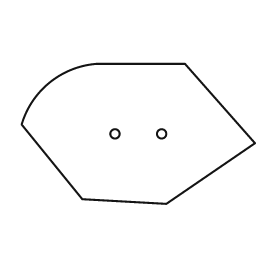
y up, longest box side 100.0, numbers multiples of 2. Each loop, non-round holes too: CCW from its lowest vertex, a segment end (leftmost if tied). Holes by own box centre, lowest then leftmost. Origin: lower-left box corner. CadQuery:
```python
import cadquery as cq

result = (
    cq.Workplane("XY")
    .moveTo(62.0, 0.0)
    .lineTo(100.0, 26.0)
    .lineTo(70.0, 60.0)
    .lineTo(32.0, 60.0)
    .threePointArc((12.0, 52.0), (0.0, 34.0))
    .lineTo(26.0, 2.0)
    .close()
    .moveTo(40.0, 30.0)
    .circle(2.0)
    .moveTo(60.0, 30.0)
    .circle(2.0)
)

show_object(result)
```